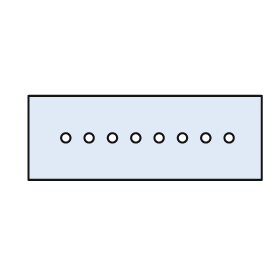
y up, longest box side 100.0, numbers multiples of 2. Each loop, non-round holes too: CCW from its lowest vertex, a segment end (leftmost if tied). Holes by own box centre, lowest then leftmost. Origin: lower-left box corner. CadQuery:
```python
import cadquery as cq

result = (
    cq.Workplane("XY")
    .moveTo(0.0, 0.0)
    .lineTo(100.0, 0.0)
    .lineTo(100.0, 36.0)
    .lineTo(0.0, 36.0)
    .close()
    .moveTo(16.0, 18.0)
    .circle(2.0)
    .moveTo(26.0, 18.0)
    .circle(2.0)
    .moveTo(36.0, 18.0)
    .circle(2.0)
    .moveTo(46.0, 18.0)
    .circle(2.0)
    .moveTo(56.0, 18.0)
    .circle(2.0)
    .moveTo(66.0, 18.0)
    .circle(2.0)
    .moveTo(76.0, 18.0)
    .circle(2.0)
    .moveTo(86.0, 18.0)
    .circle(2.0)
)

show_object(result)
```